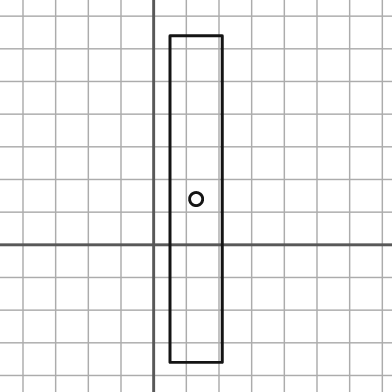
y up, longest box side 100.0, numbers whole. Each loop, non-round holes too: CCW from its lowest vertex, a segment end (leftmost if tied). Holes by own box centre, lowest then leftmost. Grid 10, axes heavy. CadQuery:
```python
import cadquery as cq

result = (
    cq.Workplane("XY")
    .moveTo(5.0, -36.0)
    .lineTo(21.0, -36.0)
    .lineTo(21.0, 64.0)
    .lineTo(5.0, 64.0)
    .close()
    .moveTo(13.0, 14.0)
    .circle(2.0)
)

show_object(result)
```